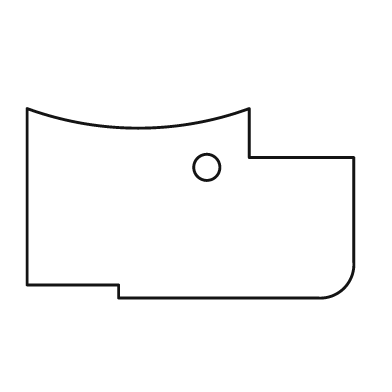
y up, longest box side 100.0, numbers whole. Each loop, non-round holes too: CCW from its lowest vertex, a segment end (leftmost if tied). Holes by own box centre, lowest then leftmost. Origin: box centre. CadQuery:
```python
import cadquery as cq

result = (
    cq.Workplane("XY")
    .moveTo(-22.0, -29.0)
    .lineTo(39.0, -29.0)
    .threePointArc((47.0, -26.0), (50.0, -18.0))
    .lineTo(50.0, 14.0)
    .lineTo(18.0, 14.0)
    .lineTo(18.0, 29.0)
    .threePointArc((-16.0, 23.0), (-50.0, 29.0))
    .lineTo(-50.0, -25.0)
    .lineTo(-22.0, -25.0)
    .close()
    .moveTo(5.0, 11.0)
    .circle(4.0)
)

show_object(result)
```